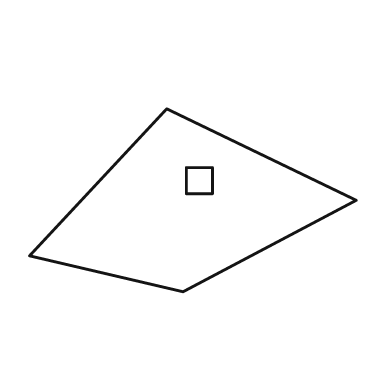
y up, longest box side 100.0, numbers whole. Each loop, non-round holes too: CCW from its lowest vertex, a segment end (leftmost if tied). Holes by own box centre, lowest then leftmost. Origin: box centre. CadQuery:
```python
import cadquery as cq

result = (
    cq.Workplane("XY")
    .moveTo(-3.0, -28.0)
    .lineTo(50.0, 0.0)
    .lineTo(-8.0, 28.0)
    .lineTo(-50.0, -17.0)
    .close()
    .moveTo(-2.0, 2.0)
    .lineTo(6.0, 2.0)
    .lineTo(6.0, 10.0)
    .lineTo(-2.0, 10.0)
    .close()
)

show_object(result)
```